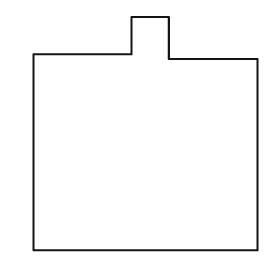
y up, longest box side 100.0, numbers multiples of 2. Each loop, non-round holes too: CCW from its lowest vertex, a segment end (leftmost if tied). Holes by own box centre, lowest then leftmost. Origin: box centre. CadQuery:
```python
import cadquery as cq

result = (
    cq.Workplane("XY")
    .moveTo(-48.0, -50.0)
    .lineTo(48.0, -50.0)
    .lineTo(48.0, 32.0)
    .lineTo(10.0, 32.0)
    .lineTo(10.0, 50.0)
    .lineTo(-6.0, 50.0)
    .lineTo(-6.0, 34.0)
    .lineTo(-48.0, 34.0)
    .close()
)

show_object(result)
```